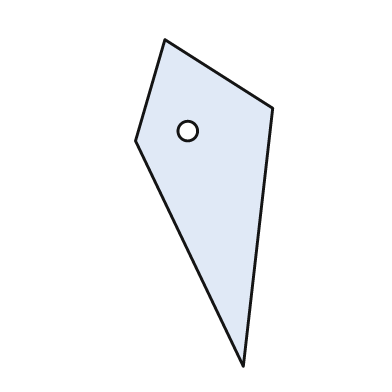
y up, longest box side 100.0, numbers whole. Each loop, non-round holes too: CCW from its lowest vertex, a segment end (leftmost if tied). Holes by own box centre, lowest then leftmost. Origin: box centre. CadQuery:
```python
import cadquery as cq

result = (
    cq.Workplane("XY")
    .moveTo(12.0, -50.0)
    .lineTo(21.0, 29.0)
    .lineTo(-12.0, 50.0)
    .lineTo(-21.0, 19.0)
    .close()
    .moveTo(-5.0, 22.0)
    .circle(3.0)
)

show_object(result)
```